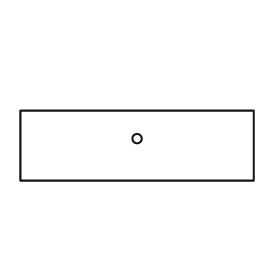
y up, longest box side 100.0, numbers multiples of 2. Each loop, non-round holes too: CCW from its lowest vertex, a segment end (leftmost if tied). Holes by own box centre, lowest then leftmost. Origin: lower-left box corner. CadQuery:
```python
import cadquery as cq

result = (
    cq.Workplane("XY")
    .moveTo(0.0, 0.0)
    .lineTo(100.0, 0.0)
    .lineTo(100.0, 30.0)
    .lineTo(0.0, 30.0)
    .close()
    .moveTo(50.0, 18.0)
    .circle(2.0)
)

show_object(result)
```